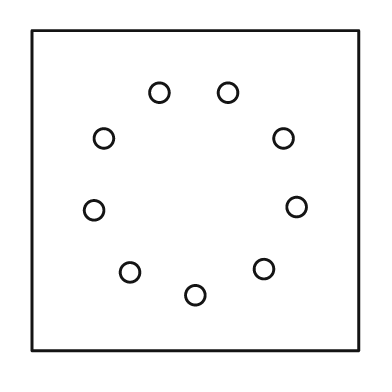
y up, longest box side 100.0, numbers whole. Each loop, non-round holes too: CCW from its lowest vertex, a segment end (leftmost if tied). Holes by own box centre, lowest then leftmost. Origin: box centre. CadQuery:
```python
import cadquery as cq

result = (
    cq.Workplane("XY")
    .moveTo(-50.0, -49.0)
    .lineTo(50.0, -49.0)
    .lineTo(50.0, 49.0)
    .lineTo(-50.0, 49.0)
    .close()
    .moveTo(0.0, -32.0)
    .circle(3.0)
    .moveTo(-20.0, -25.0)
    .circle(3.0)
    .moveTo(21.0, -24.0)
    .circle(3.0)
    .moveTo(-31.0, -6.0)
    .circle(3.0)
    .moveTo(31.0, -5.0)
    .circle(3.0)
    .moveTo(-28.0, 16.0)
    .circle(3.0)
    .moveTo(27.0, 16.0)
    .circle(3.0)
    .moveTo(-11.0, 30.0)
    .circle(3.0)
    .moveTo(10.0, 30.0)
    .circle(3.0)
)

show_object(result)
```